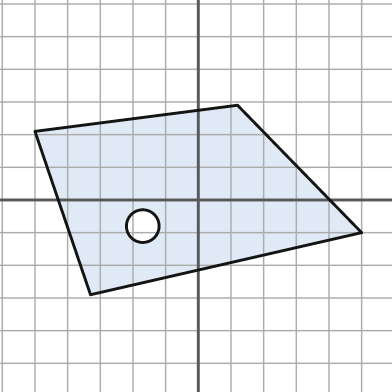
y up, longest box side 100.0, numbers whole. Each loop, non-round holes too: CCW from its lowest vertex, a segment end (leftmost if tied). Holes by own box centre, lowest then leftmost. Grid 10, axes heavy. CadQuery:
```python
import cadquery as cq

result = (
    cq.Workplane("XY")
    .moveTo(-33.0, -29.0)
    .lineTo(50.0, -10.0)
    .lineTo(12.0, 29.0)
    .lineTo(-50.0, 21.0)
    .close()
    .moveTo(-17.0, -8.0)
    .circle(5.0)
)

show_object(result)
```